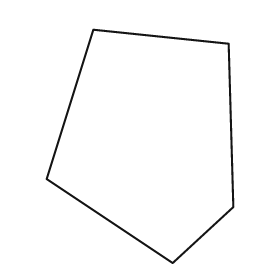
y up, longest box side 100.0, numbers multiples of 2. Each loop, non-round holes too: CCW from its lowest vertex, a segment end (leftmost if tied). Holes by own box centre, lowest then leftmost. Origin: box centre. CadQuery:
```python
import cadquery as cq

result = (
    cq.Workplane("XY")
    .moveTo(14.0, -50.0)
    .lineTo(40.0, -26.0)
    .lineTo(38.0, 44.0)
    .lineTo(-20.0, 50.0)
    .lineTo(-40.0, -14.0)
    .close()
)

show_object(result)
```